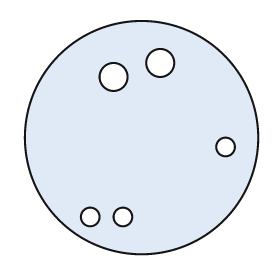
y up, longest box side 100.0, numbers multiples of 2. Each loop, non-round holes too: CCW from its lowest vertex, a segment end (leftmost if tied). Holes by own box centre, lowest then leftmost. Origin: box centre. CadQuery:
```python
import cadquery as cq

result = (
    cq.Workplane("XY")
    .moveTo(0.0, 0.0)
    .circle(50.0)
    .moveTo(-22.0, -34.0)
    .circle(4.0)
    .moveTo(-8.0, -34.0)
    .circle(4.0)
    .moveTo(36.0, -4.0)
    .circle(4.0)
    .moveTo(-12.0, 26.0)
    .circle(6.0)
    .moveTo(8.0, 32.0)
    .circle(6.0)
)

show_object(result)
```